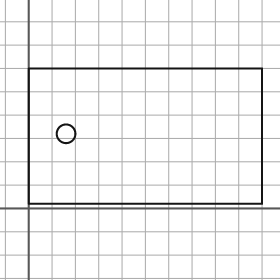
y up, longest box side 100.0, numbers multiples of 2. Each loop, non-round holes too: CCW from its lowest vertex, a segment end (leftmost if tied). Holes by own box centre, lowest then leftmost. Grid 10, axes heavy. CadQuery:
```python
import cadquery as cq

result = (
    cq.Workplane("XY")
    .moveTo(0.0, 2.0)
    .lineTo(100.0, 2.0)
    .lineTo(100.0, 60.0)
    .lineTo(0.0, 60.0)
    .close()
    .moveTo(16.0, 32.0)
    .circle(4.0)
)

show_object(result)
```